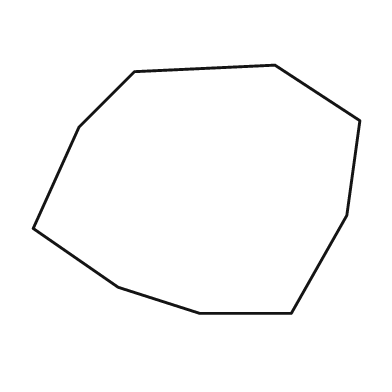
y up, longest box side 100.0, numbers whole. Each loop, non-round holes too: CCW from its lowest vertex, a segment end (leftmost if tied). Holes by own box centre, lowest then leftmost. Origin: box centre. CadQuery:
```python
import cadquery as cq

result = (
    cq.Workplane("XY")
    .moveTo(1.0, -38.0)
    .lineTo(29.0, -38.0)
    .lineTo(46.0, -8.0)
    .lineTo(50.0, 21.0)
    .lineTo(24.0, 38.0)
    .lineTo(-19.0, 36.0)
    .lineTo(-36.0, 19.0)
    .lineTo(-50.0, -12.0)
    .lineTo(-24.0, -30.0)
    .close()
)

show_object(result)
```